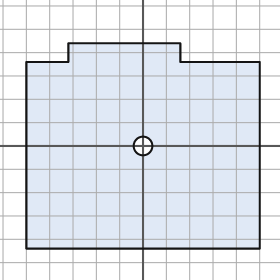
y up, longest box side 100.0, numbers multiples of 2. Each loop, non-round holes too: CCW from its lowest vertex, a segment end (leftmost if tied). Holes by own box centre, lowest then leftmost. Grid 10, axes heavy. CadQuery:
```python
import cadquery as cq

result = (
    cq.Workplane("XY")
    .moveTo(-50.0, -44.0)
    .lineTo(50.0, -44.0)
    .lineTo(50.0, 36.0)
    .lineTo(16.0, 36.0)
    .lineTo(16.0, 44.0)
    .lineTo(-32.0, 44.0)
    .lineTo(-32.0, 36.0)
    .lineTo(-50.0, 36.0)
    .close()
    .moveTo(0.0, 0.0)
    .circle(4.0)
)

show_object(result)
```